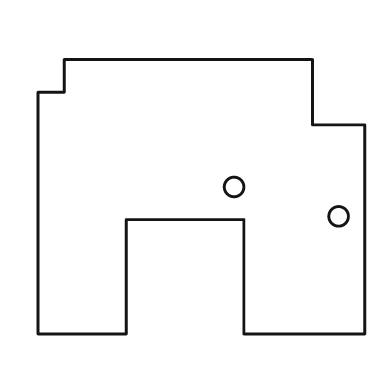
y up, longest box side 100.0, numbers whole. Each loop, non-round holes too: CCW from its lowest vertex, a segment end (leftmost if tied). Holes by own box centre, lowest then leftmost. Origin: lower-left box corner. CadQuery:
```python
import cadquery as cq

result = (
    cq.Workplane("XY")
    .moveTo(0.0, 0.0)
    .lineTo(27.0, 0.0)
    .lineTo(27.0, 35.0)
    .lineTo(63.0, 35.0)
    .lineTo(63.0, 0.0)
    .lineTo(100.0, 0.0)
    .lineTo(100.0, 64.0)
    .lineTo(84.0, 64.0)
    .lineTo(84.0, 84.0)
    .lineTo(8.0, 84.0)
    .lineTo(8.0, 74.0)
    .lineTo(0.0, 74.0)
    .close()
    .moveTo(92.0, 36.0)
    .circle(3.0)
    .moveTo(60.0, 45.0)
    .circle(3.0)
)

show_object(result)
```